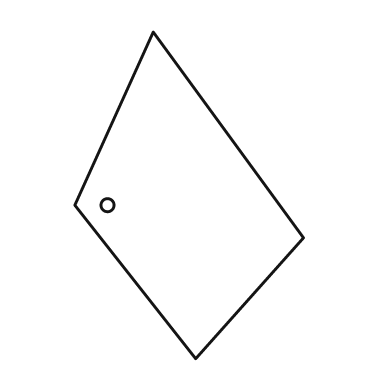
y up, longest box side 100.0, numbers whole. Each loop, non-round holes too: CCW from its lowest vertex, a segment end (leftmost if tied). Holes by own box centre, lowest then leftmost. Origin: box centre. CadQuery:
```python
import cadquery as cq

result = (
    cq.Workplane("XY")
    .moveTo(2.0, -50.0)
    .lineTo(35.0, -13.0)
    .lineTo(-11.0, 50.0)
    .lineTo(-35.0, -3.0)
    .close()
    .moveTo(-25.0, -3.0)
    .circle(2.0)
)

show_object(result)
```